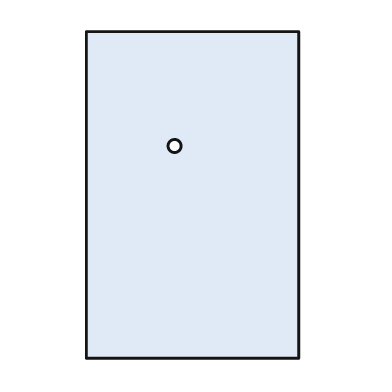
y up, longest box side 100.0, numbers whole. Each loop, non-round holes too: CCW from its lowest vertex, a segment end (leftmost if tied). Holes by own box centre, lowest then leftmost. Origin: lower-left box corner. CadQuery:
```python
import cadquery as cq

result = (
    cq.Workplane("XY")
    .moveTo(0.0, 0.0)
    .lineTo(65.0, 0.0)
    .lineTo(65.0, 100.0)
    .lineTo(0.0, 100.0)
    .close()
    .moveTo(27.0, 65.0)
    .circle(2.0)
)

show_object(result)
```